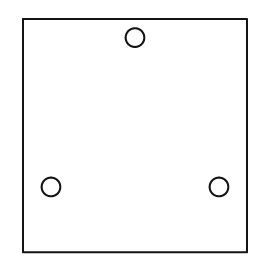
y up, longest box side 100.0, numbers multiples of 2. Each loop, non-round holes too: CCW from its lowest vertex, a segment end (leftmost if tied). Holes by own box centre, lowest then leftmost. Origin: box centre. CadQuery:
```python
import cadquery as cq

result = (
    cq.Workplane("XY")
    .moveTo(-48.0, -50.0)
    .lineTo(48.0, -50.0)
    .lineTo(48.0, 50.0)
    .lineTo(-48.0, 50.0)
    .close()
    .moveTo(-36.0, -22.0)
    .circle(4.0)
    .moveTo(36.0, -22.0)
    .circle(4.0)
    .moveTo(0.0, 42.0)
    .circle(4.0)
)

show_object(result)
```